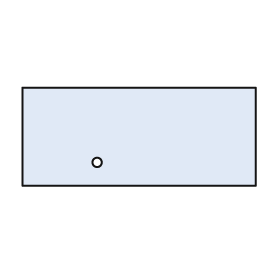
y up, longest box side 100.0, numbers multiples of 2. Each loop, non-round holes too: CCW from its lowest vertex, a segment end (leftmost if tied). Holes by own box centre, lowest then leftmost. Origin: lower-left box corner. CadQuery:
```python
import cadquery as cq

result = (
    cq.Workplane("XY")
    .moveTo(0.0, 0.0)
    .lineTo(100.0, 0.0)
    .lineTo(100.0, 42.0)
    .lineTo(0.0, 42.0)
    .close()
    .moveTo(32.0, 10.0)
    .circle(2.0)
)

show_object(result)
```